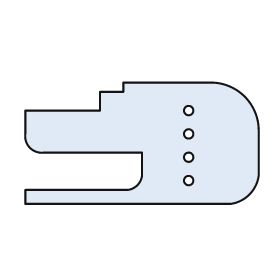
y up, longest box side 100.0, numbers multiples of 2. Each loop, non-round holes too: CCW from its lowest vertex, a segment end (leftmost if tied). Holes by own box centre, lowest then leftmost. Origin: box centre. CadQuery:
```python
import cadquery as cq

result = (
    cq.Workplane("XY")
    .moveTo(-50.0, -26.0)
    .lineTo(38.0, -26.0)
    .threePointArc((46.0, -22.0), (50.0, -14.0))
    .lineTo(50.0, 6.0)
    .threePointArc((44.0, 20.0), (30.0, 26.0))
    .lineTo(-8.0, 26.0)
    .lineTo(-8.0, 22.0)
    .lineTo(-18.0, 22.0)
    .lineTo(-18.0, 14.0)
    .lineTo(-50.0, 14.0)
    .lineTo(-50.0, 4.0)
    .threePointArc((-48.0, -2.0), (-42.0, -4.0))
    .lineTo(0.0, -4.0)
    .lineTo(0.0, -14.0)
    .threePointArc((-2.0, -18.0), (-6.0, -20.0))
    .lineTo(-50.0, -20.0)
    .close()
    .moveTo(20.0, -16.0)
    .circle(2.0)
    .moveTo(20.0, -6.0)
    .circle(2.0)
    .moveTo(20.0, 4.0)
    .circle(2.0)
    .moveTo(20.0, 14.0)
    .circle(2.0)
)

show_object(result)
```